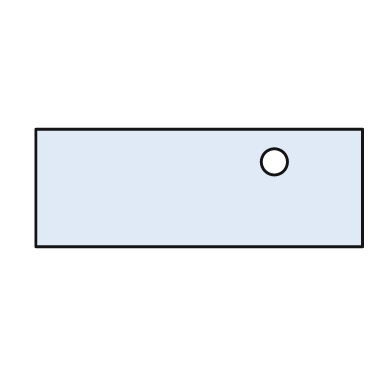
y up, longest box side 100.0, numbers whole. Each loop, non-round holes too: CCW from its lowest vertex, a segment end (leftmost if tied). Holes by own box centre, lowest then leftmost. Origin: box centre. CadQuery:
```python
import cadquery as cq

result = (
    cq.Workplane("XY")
    .moveTo(-50.0, -18.0)
    .lineTo(50.0, -18.0)
    .lineTo(50.0, 18.0)
    .lineTo(-50.0, 18.0)
    .close()
    .moveTo(23.0, 8.0)
    .circle(4.0)
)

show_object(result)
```